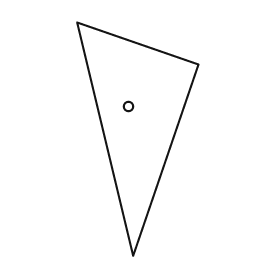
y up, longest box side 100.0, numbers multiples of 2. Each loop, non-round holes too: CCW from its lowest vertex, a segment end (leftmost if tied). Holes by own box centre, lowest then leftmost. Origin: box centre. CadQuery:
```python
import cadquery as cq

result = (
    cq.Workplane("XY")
    .moveTo(-2.0, -50.0)
    .lineTo(26.0, 32.0)
    .lineTo(-26.0, 50.0)
    .close()
    .moveTo(-4.0, 14.0)
    .circle(2.0)
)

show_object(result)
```